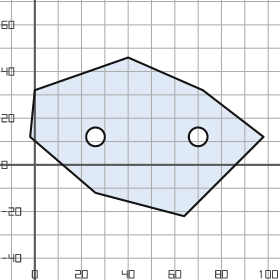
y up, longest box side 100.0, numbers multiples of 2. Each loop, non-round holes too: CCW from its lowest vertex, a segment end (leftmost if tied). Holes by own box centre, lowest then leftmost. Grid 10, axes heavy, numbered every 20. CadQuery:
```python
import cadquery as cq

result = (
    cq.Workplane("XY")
    .moveTo(64.0, -22.0)
    .lineTo(98.0, 12.0)
    .lineTo(72.0, 32.0)
    .lineTo(40.0, 46.0)
    .lineTo(0.0, 32.0)
    .lineTo(-2.0, 12.0)
    .lineTo(26.0, -12.0)
    .close()
    .moveTo(26.0, 12.0)
    .circle(4.0)
    .moveTo(70.0, 12.0)
    .circle(4.0)
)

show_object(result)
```